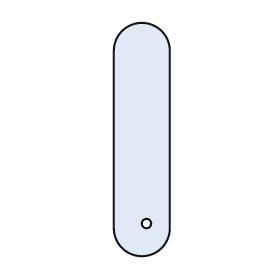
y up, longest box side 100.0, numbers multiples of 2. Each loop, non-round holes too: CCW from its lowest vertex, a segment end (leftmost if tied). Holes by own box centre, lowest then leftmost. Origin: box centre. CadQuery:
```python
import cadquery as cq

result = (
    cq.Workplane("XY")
    .moveTo(-12.0, -38.0)
    .threePointArc((0.0, -50.0), (12.0, -38.0))
    .lineTo(12.0, 38.0)
    .threePointArc((0.0, 50.0), (-12.0, 38.0))
    .close()
    .moveTo(2.0, -36.0)
    .circle(2.0)
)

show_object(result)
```